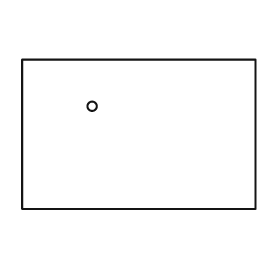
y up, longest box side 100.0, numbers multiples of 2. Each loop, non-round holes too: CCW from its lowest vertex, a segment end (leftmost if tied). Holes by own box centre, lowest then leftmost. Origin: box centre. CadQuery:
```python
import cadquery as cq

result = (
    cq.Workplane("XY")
    .moveTo(-50.0, -32.0)
    .lineTo(50.0, -32.0)
    .lineTo(50.0, 32.0)
    .lineTo(-50.0, 32.0)
    .close()
    .moveTo(-20.0, 12.0)
    .circle(2.0)
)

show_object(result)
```